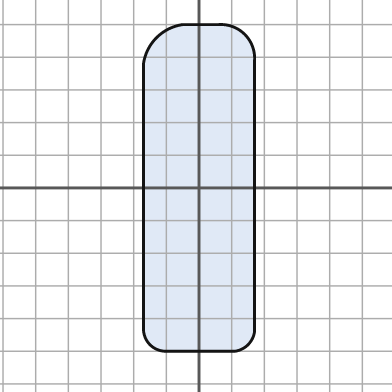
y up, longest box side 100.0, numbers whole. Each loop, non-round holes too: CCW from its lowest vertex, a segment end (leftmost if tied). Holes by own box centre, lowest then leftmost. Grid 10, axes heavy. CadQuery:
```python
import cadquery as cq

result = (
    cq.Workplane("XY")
    .moveTo(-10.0, -50.0)
    .lineTo(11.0, -50.0)
    .threePointArc((15.0, -48.0), (17.0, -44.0))
    .lineTo(17.0, 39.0)
    .threePointArc((14.0, 47.0), (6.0, 50.0))
    .lineTo(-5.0, 50.0)
    .threePointArc((-13.0, 46.0), (-17.0, 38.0))
    .lineTo(-17.0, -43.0)
    .threePointArc((-15.0, -48.0), (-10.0, -50.0))
    .close()
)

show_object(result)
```